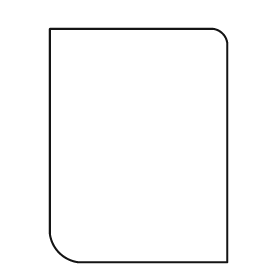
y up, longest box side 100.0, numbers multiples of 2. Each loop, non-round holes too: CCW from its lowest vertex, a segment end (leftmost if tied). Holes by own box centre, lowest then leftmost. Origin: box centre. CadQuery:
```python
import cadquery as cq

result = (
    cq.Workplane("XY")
    .moveTo(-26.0, -50.0)
    .lineTo(38.0, -50.0)
    .lineTo(38.0, 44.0)
    .threePointArc((36.0, 48.0), (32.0, 50.0))
    .lineTo(-38.0, 50.0)
    .lineTo(-38.0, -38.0)
    .threePointArc((-34.0, -46.0), (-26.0, -50.0))
    .close()
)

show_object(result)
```